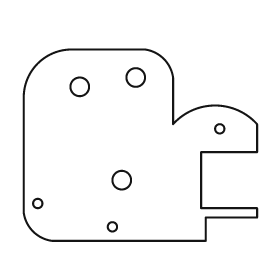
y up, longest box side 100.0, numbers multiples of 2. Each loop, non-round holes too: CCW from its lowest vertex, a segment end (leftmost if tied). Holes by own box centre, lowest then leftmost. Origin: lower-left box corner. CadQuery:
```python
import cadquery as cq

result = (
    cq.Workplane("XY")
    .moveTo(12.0, 0.0)
    .lineTo(78.0, 0.0)
    .lineTo(78.0, 10.0)
    .lineTo(100.0, 10.0)
    .lineTo(100.0, 14.0)
    .lineTo(76.0, 14.0)
    .lineTo(76.0, 38.0)
    .lineTo(100.0, 38.0)
    .lineTo(100.0, 50.0)
    .threePointArc((82.0, 58.0), (64.0, 50.0))
    .lineTo(64.0, 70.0)
    .threePointArc((60.0, 78.0), (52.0, 82.0))
    .lineTo(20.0, 82.0)
    .threePointArc((6.0, 76.0), (0.0, 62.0))
    .lineTo(0.0, 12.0)
    .threePointArc((4.0, 4.0), (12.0, 0.0))
    .close()
    .moveTo(38.0, 6.0)
    .circle(2.0)
    .moveTo(6.0, 16.0)
    .circle(2.0)
    .moveTo(42.0, 26.0)
    .circle(4.0)
    .moveTo(84.0, 48.0)
    .circle(2.0)
    .moveTo(24.0, 66.0)
    .circle(4.0)
    .moveTo(48.0, 70.0)
    .circle(4.0)
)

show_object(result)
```